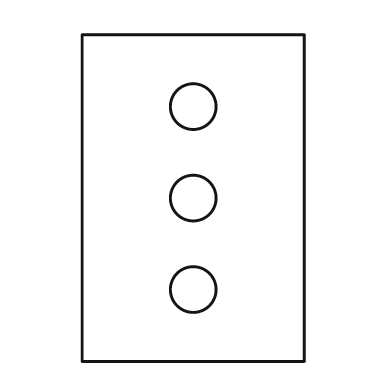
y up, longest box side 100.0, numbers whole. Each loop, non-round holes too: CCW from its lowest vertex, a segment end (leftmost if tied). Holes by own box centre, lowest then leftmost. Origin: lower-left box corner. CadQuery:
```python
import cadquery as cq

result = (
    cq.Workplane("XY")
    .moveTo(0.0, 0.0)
    .lineTo(68.0, 0.0)
    .lineTo(68.0, 100.0)
    .lineTo(0.0, 100.0)
    .close()
    .moveTo(34.0, 22.0)
    .circle(7.0)
    .moveTo(34.0, 50.0)
    .circle(7.0)
    .moveTo(34.0, 78.0)
    .circle(7.0)
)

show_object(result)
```